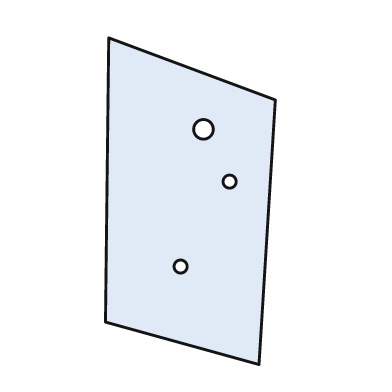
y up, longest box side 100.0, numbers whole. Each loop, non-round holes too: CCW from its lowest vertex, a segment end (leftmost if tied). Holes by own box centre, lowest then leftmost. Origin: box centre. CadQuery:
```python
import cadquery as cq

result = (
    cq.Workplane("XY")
    .moveTo(21.0, -50.0)
    .lineTo(26.0, 31.0)
    .lineTo(-25.0, 50.0)
    .lineTo(-26.0, -37.0)
    .close()
    .moveTo(-3.0, -20.0)
    .circle(2.0)
    .moveTo(12.0, 6.0)
    .circle(2.0)
    .moveTo(4.0, 22.0)
    .circle(3.0)
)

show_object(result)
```